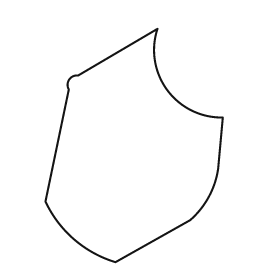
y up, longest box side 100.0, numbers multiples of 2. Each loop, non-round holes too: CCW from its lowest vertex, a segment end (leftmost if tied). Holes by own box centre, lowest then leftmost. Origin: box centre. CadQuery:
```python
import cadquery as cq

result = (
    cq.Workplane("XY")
    .moveTo(-8.0, -50.0)
    .lineTo(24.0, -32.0)
    .threePointArc((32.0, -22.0), (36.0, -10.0))
    .lineTo(38.0, 12.0)
    .threePointArc((14.0, 24.0), (10.0, 50.0))
    .lineTo(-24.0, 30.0)
    .threePointArc((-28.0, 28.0), (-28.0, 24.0))
    .lineTo(-38.0, -24.0)
    .threePointArc((-26.0, -40.0), (-8.0, -50.0))
    .close()
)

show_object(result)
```